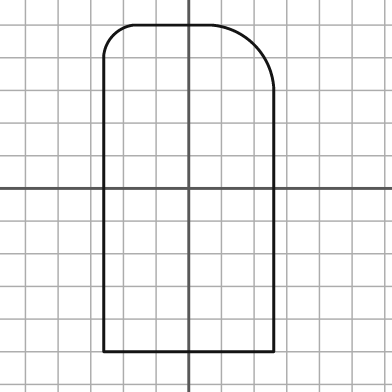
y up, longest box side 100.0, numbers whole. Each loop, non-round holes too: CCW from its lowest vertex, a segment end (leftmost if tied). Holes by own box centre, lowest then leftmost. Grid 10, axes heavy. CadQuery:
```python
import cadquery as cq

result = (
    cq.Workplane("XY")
    .moveTo(-26.0, -50.0)
    .lineTo(26.0, -50.0)
    .lineTo(26.0, 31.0)
    .threePointArc((20.0, 44.0), (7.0, 50.0))
    .lineTo(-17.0, 50.0)
    .threePointArc((-23.0, 47.0), (-26.0, 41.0))
    .close()
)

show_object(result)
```